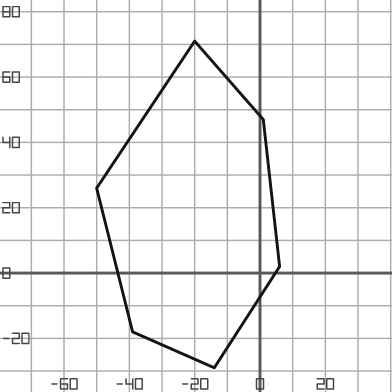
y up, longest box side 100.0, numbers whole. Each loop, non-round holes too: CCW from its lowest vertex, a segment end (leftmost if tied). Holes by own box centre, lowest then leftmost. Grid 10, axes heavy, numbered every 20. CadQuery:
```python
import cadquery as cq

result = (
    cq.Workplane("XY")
    .moveTo(-14.0, -29.0)
    .lineTo(6.0, 2.0)
    .lineTo(1.0, 47.0)
    .lineTo(-20.0, 71.0)
    .lineTo(-50.0, 26.0)
    .lineTo(-39.0, -18.0)
    .close()
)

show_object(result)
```